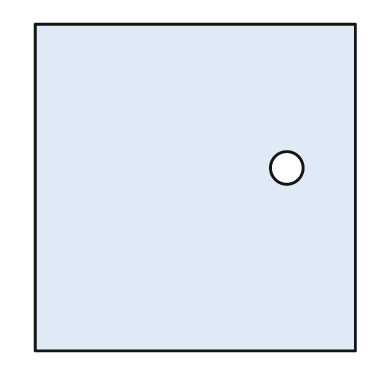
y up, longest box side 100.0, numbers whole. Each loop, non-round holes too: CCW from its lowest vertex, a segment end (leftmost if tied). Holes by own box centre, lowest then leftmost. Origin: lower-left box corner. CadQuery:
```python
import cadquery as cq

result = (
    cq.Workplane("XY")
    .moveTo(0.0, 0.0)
    .lineTo(98.0, 0.0)
    .lineTo(98.0, 100.0)
    .lineTo(0.0, 100.0)
    .close()
    .moveTo(77.0, 56.0)
    .circle(5.0)
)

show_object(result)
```